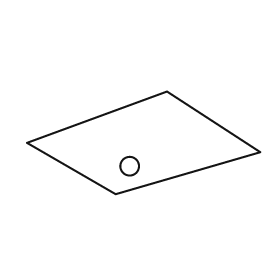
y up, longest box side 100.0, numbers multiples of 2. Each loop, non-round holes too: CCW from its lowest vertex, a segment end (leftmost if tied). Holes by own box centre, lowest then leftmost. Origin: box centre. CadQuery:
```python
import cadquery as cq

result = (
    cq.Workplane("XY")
    .moveTo(-12.0, -22.0)
    .lineTo(50.0, -4.0)
    .lineTo(10.0, 22.0)
    .lineTo(-50.0, 0.0)
    .close()
    .moveTo(-6.0, -10.0)
    .circle(4.0)
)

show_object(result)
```